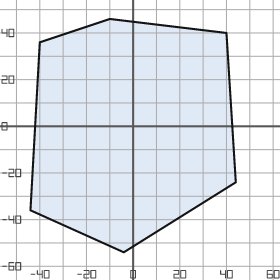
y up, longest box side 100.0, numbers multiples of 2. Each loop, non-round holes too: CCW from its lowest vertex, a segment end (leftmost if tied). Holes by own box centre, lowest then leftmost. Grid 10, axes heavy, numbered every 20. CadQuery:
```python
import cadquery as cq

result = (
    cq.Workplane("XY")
    .moveTo(-4.0, -54.0)
    .lineTo(44.0, -24.0)
    .lineTo(40.0, 40.0)
    .lineTo(-10.0, 46.0)
    .lineTo(-40.0, 36.0)
    .lineTo(-44.0, -36.0)
    .close()
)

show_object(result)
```